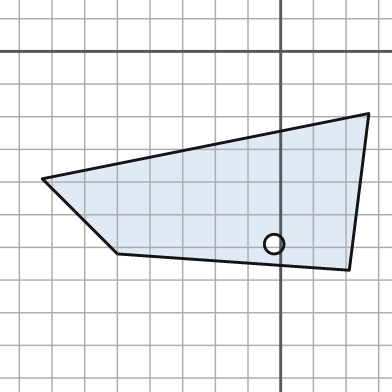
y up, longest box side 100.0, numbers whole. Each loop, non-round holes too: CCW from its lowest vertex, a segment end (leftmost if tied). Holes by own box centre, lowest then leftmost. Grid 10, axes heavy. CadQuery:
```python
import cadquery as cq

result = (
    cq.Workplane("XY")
    .moveTo(21.0, -67.0)
    .lineTo(27.0, -19.0)
    .lineTo(-73.0, -39.0)
    .lineTo(-50.0, -62.0)
    .close()
    .moveTo(-2.0, -59.0)
    .circle(3.0)
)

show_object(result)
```